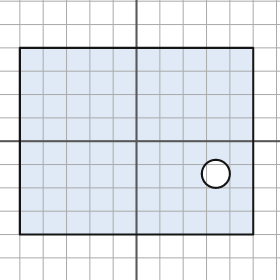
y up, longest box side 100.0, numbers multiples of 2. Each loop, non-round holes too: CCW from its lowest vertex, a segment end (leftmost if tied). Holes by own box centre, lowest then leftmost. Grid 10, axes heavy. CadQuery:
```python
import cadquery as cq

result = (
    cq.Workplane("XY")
    .moveTo(-50.0, -40.0)
    .lineTo(50.0, -40.0)
    .lineTo(50.0, 40.0)
    .lineTo(-50.0, 40.0)
    .close()
    .moveTo(34.0, -14.0)
    .circle(6.0)
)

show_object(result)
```